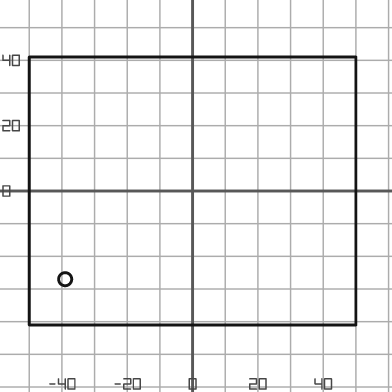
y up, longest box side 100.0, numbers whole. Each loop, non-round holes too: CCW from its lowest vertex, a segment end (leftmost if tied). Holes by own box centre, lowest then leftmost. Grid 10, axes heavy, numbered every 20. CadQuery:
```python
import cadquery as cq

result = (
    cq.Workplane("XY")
    .moveTo(-50.0, -41.0)
    .lineTo(50.0, -41.0)
    .lineTo(50.0, 41.0)
    .lineTo(-50.0, 41.0)
    .close()
    .moveTo(-39.0, -27.0)
    .circle(2.0)
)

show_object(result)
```